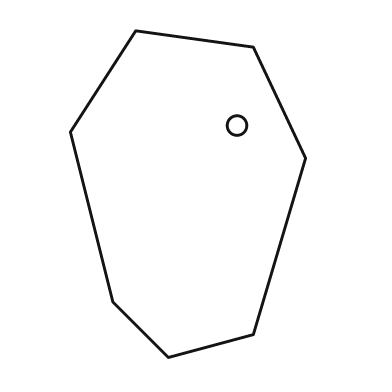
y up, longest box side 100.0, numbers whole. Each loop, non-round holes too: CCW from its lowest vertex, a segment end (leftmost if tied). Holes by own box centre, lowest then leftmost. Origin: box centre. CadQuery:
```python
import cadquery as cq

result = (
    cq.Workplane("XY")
    .moveTo(-6.0, -50.0)
    .lineTo(20.0, -43.0)
    .lineTo(36.0, 11.0)
    .lineTo(20.0, 45.0)
    .lineTo(-16.0, 50.0)
    .lineTo(-36.0, 19.0)
    .lineTo(-23.0, -33.0)
    .close()
    .moveTo(15.0, 21.0)
    .circle(3.0)
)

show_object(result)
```